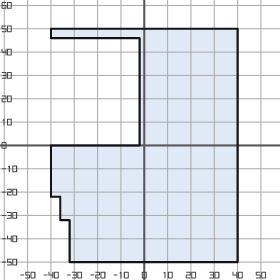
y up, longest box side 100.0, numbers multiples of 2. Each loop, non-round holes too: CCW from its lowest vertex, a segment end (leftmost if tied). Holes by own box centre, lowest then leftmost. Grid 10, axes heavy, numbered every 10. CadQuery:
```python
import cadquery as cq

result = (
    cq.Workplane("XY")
    .moveTo(-32.0, -50.0)
    .lineTo(40.0, -50.0)
    .lineTo(40.0, 50.0)
    .lineTo(-40.0, 50.0)
    .lineTo(-40.0, 46.0)
    .lineTo(-2.0, 46.0)
    .lineTo(-2.0, 0.0)
    .lineTo(-40.0, 0.0)
    .lineTo(-40.0, -22.0)
    .lineTo(-36.0, -22.0)
    .lineTo(-36.0, -32.0)
    .lineTo(-32.0, -32.0)
    .close()
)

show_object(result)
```